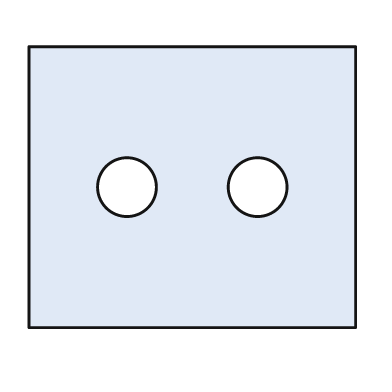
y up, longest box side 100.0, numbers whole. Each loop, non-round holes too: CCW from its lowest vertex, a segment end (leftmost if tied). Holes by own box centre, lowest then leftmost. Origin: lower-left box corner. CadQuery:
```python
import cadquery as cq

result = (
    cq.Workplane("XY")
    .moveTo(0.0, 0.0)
    .lineTo(100.0, 0.0)
    .lineTo(100.0, 86.0)
    .lineTo(0.0, 86.0)
    .close()
    .moveTo(30.0, 43.0)
    .circle(9.0)
    .moveTo(70.0, 43.0)
    .circle(9.0)
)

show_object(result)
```